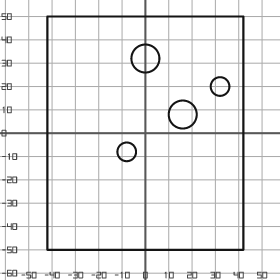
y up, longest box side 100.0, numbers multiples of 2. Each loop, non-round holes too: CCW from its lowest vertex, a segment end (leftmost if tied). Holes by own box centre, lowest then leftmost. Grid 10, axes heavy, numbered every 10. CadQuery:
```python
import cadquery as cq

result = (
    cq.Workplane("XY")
    .moveTo(-42.0, -50.0)
    .lineTo(42.0, -50.0)
    .lineTo(42.0, 50.0)
    .lineTo(-42.0, 50.0)
    .close()
    .moveTo(-8.0, -8.0)
    .circle(4.0)
    .moveTo(16.0, 8.0)
    .circle(6.0)
    .moveTo(32.0, 20.0)
    .circle(4.0)
    .moveTo(0.0, 32.0)
    .circle(6.0)
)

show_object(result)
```